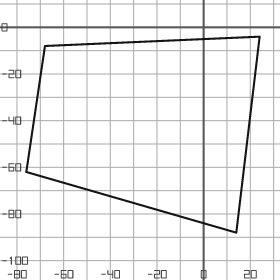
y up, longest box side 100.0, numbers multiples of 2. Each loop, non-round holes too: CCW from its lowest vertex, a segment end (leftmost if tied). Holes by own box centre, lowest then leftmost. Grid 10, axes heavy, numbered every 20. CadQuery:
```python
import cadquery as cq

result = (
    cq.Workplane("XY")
    .moveTo(14.0, -88.0)
    .lineTo(24.0, -4.0)
    .lineTo(-68.0, -8.0)
    .lineTo(-76.0, -62.0)
    .close()
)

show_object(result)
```